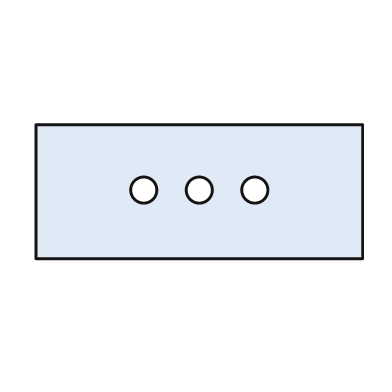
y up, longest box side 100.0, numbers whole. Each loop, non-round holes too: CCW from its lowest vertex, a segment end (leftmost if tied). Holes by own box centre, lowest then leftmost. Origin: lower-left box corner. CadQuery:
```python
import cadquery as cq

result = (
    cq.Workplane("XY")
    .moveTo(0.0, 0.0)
    .lineTo(100.0, 0.0)
    .lineTo(100.0, 41.0)
    .lineTo(0.0, 41.0)
    .close()
    .moveTo(33.0, 21.0)
    .circle(4.0)
    .moveTo(50.0, 21.0)
    .circle(4.0)
    .moveTo(67.0, 21.0)
    .circle(4.0)
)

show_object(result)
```